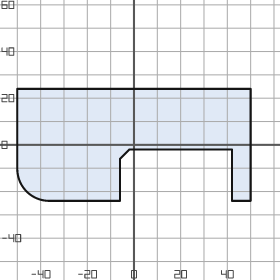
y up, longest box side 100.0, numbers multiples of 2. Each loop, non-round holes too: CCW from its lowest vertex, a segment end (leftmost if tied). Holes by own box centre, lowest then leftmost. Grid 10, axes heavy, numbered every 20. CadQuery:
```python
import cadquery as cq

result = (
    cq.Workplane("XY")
    .moveTo(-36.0, -24.0)
    .lineTo(-6.0, -24.0)
    .lineTo(-6.0, -6.0)
    .lineTo(-2.0, -2.0)
    .lineTo(42.0, -2.0)
    .lineTo(42.0, -24.0)
    .lineTo(50.0, -24.0)
    .lineTo(50.0, 24.0)
    .lineTo(-50.0, 24.0)
    .lineTo(-50.0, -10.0)
    .threePointArc((-46.0, -20.0), (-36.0, -24.0))
    .close()
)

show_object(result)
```